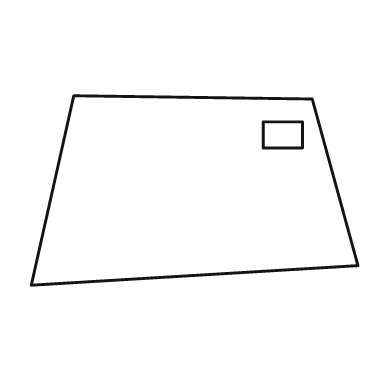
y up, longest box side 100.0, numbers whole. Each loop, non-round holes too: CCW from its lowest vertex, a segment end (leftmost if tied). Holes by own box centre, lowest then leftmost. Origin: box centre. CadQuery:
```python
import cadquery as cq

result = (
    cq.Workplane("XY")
    .moveTo(-50.0, -29.0)
    .lineTo(50.0, -23.0)
    .lineTo(36.0, 28.0)
    .lineTo(-37.0, 29.0)
    .close()
    .moveTo(21.0, 13.0)
    .lineTo(33.0, 13.0)
    .lineTo(33.0, 21.0)
    .lineTo(21.0, 21.0)
    .close()
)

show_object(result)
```